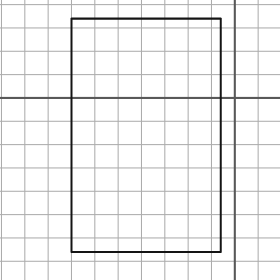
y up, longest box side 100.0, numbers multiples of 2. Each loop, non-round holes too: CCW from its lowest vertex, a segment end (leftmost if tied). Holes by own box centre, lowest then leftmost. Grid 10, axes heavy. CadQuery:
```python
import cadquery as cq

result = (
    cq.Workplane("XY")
    .moveTo(-70.0, -66.0)
    .lineTo(-6.0, -66.0)
    .lineTo(-6.0, 34.0)
    .lineTo(-70.0, 34.0)
    .close()
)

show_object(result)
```